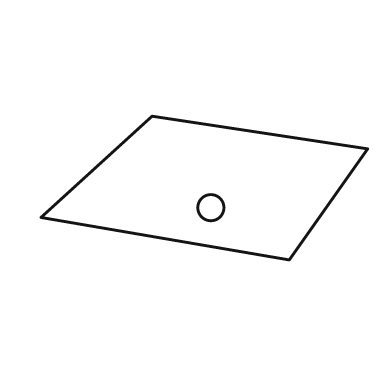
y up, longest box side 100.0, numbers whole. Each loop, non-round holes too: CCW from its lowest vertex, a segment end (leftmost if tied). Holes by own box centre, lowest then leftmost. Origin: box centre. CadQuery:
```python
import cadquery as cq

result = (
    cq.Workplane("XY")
    .moveTo(26.0, -22.0)
    .lineTo(50.0, 12.0)
    .lineTo(-16.0, 22.0)
    .lineTo(-50.0, -9.0)
    .close()
    .moveTo(2.0, -6.0)
    .circle(4.0)
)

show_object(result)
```